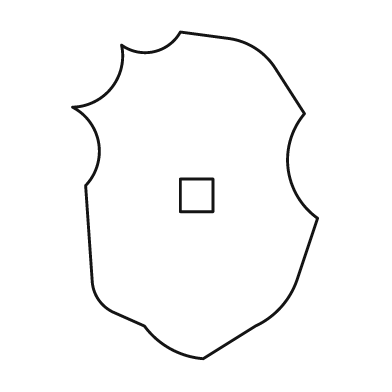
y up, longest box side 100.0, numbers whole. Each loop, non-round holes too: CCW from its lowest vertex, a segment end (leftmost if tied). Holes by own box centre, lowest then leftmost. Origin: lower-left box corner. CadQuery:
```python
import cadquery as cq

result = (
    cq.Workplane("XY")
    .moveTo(40.0, 0.0)
    .lineTo(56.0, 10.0)
    .threePointArc((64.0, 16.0), (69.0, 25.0))
    .lineTo(75.0, 43.0)
    .threePointArc((66.0, 58.0), (71.0, 75.0))
    .lineTo(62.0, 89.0)
    .threePointArc((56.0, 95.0), (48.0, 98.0))
    .lineTo(33.0, 100.0)
    .threePointArc((25.0, 94.0), (15.0, 96.0))
    .threePointArc((12.0, 83.0), (0.0, 77.0))
    .threePointArc((8.0, 66.0), (4.0, 53.0))
    .lineTo(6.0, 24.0)
    .threePointArc((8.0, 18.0), (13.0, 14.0))
    .lineTo(22.0, 10.0)
    .threePointArc((30.0, 3.0), (40.0, 0.0))
    .close()
    .moveTo(33.0, 45.0)
    .lineTo(43.0, 45.0)
    .lineTo(43.0, 55.0)
    .lineTo(33.0, 55.0)
    .close()
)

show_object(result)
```